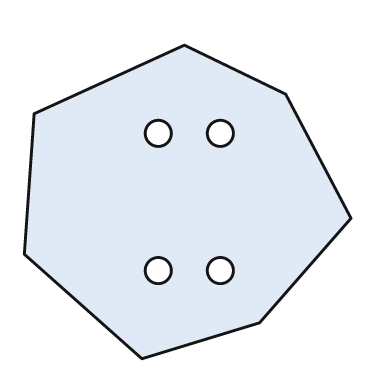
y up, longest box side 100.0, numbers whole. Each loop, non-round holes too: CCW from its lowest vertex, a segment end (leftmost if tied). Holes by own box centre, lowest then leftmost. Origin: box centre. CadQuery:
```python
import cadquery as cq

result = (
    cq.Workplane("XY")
    .moveTo(-14.0, -48.0)
    .lineTo(22.0, -37.0)
    .lineTo(50.0, -5.0)
    .lineTo(30.0, 33.0)
    .lineTo(-1.0, 48.0)
    .lineTo(-47.0, 27.0)
    .lineTo(-50.0, -16.0)
    .close()
    .moveTo(-9.0, -21.0)
    .circle(4.0)
    .moveTo(10.0, -21.0)
    .circle(4.0)
    .moveTo(-9.0, 21.0)
    .circle(4.0)
    .moveTo(10.0, 21.0)
    .circle(4.0)
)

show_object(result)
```